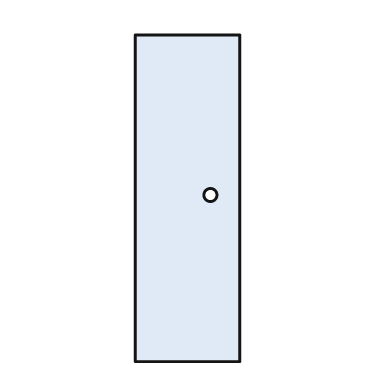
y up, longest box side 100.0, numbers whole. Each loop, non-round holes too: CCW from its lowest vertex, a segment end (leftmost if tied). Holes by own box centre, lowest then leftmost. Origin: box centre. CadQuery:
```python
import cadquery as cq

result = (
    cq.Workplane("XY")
    .moveTo(-16.0, -50.0)
    .lineTo(16.0, -50.0)
    .lineTo(16.0, 50.0)
    .lineTo(-16.0, 50.0)
    .close()
    .moveTo(7.0, 1.0)
    .circle(2.0)
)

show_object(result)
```